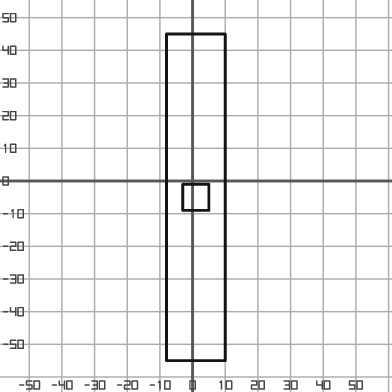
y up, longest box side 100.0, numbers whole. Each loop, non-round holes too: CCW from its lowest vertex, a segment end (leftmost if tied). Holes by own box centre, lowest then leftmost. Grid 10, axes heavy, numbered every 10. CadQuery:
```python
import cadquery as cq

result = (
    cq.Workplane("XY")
    .moveTo(-8.0, -55.0)
    .lineTo(10.0, -55.0)
    .lineTo(10.0, 45.0)
    .lineTo(-8.0, 45.0)
    .close()
    .moveTo(-3.0, -9.0)
    .lineTo(5.0, -9.0)
    .lineTo(5.0, -1.0)
    .lineTo(-3.0, -1.0)
    .close()
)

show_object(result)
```